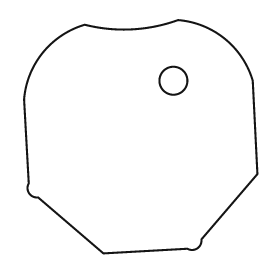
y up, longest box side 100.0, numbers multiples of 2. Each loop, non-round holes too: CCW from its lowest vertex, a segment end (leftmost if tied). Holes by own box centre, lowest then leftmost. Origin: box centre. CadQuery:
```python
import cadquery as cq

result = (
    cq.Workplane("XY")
    .moveTo(-16.0, -50.0)
    .lineTo(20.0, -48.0)
    .threePointArc((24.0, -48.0), (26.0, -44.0))
    .lineTo(50.0, -16.0)
    .lineTo(48.0, 24.0)
    .threePointArc((36.0, 42.0), (16.0, 50.0))
    .threePointArc((-4.0, 46.0), (-24.0, 48.0))
    .threePointArc((-42.0, 36.0), (-50.0, 16.0))
    .lineTo(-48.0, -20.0)
    .threePointArc((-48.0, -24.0), (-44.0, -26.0))
    .close()
    .moveTo(14.0, 24.0)
    .circle(6.0)
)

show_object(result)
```